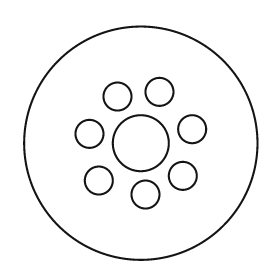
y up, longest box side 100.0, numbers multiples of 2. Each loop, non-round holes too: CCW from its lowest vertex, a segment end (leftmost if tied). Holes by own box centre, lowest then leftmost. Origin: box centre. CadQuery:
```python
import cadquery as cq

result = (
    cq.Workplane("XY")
    .moveTo(0.0, 0.0)
    .circle(50.0)
    .moveTo(2.0, -22.0)
    .circle(6.0)
    .moveTo(-18.0, -16.0)
    .circle(6.0)
    .moveTo(18.0, -14.0)
    .circle(6.0)
    .moveTo(0.0, 0.0)
    .circle(12.0)
    .moveTo(-22.0, 4.0)
    .circle(6.0)
    .moveTo(22.0, 6.0)
    .circle(6.0)
    .moveTo(-10.0, 20.0)
    .circle(6.0)
    .moveTo(8.0, 22.0)
    .circle(6.0)
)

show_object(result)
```